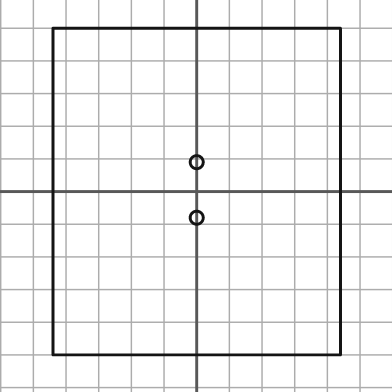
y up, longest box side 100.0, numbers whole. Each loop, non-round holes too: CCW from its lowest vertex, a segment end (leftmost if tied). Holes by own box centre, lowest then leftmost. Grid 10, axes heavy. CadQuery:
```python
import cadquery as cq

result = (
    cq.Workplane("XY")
    .moveTo(-44.0, -50.0)
    .lineTo(44.0, -50.0)
    .lineTo(44.0, 50.0)
    .lineTo(-44.0, 50.0)
    .close()
    .moveTo(0.0, -8.0)
    .circle(2.0)
    .moveTo(0.0, 9.0)
    .circle(2.0)
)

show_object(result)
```